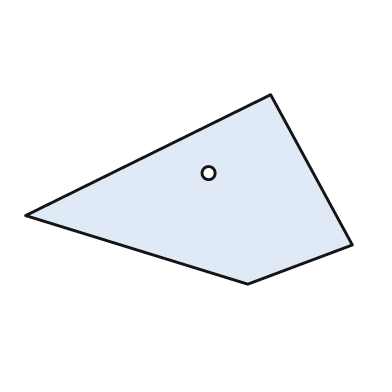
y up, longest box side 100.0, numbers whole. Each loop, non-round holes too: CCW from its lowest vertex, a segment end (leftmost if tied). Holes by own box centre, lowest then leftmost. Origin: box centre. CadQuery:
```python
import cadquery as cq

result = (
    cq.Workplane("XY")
    .moveTo(18.0, -29.0)
    .lineTo(50.0, -17.0)
    .lineTo(25.0, 29.0)
    .lineTo(-50.0, -8.0)
    .close()
    .moveTo(6.0, 5.0)
    .circle(2.0)
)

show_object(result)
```